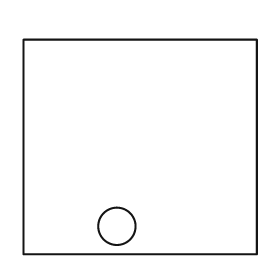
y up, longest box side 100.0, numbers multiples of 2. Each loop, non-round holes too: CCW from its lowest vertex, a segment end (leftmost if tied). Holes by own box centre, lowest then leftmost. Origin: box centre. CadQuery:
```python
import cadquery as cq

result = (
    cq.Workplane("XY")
    .moveTo(-50.0, -46.0)
    .lineTo(50.0, -46.0)
    .lineTo(50.0, 46.0)
    .lineTo(-50.0, 46.0)
    .close()
    .moveTo(-10.0, -34.0)
    .circle(8.0)
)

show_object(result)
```